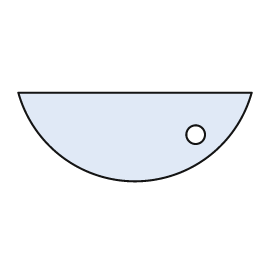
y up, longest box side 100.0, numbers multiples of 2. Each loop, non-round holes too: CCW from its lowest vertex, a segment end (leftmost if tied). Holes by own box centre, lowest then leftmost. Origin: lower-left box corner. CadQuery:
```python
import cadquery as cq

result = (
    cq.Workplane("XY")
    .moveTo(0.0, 38.0)
    .threePointArc((50.0, 0.0), (100.0, 38.0))
    .close()
    .moveTo(76.0, 20.0)
    .circle(4.0)
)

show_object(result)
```